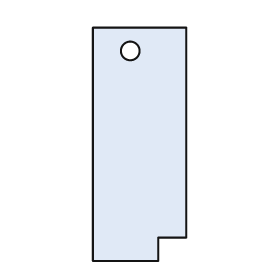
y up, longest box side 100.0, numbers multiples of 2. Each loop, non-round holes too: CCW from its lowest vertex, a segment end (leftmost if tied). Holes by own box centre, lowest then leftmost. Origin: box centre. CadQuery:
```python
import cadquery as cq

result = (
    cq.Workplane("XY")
    .moveTo(-20.0, -50.0)
    .lineTo(8.0, -50.0)
    .lineTo(8.0, -40.0)
    .lineTo(20.0, -40.0)
    .lineTo(20.0, 50.0)
    .lineTo(-20.0, 50.0)
    .close()
    .moveTo(-4.0, 40.0)
    .circle(4.0)
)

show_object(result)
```